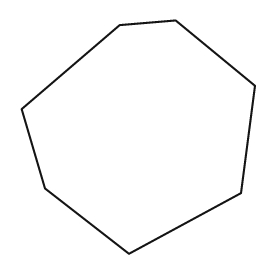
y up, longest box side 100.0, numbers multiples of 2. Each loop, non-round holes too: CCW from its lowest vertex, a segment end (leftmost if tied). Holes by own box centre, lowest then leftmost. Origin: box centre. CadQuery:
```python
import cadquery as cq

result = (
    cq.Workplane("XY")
    .moveTo(-4.0, -50.0)
    .lineTo(44.0, -24.0)
    .lineTo(50.0, 22.0)
    .lineTo(16.0, 50.0)
    .lineTo(-8.0, 48.0)
    .lineTo(-50.0, 12.0)
    .lineTo(-40.0, -22.0)
    .close()
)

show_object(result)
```